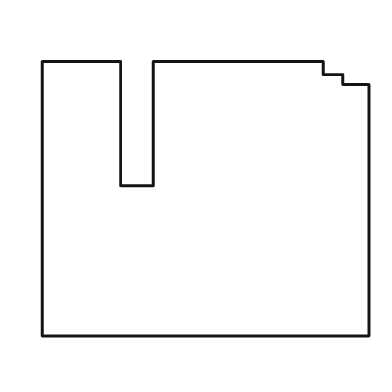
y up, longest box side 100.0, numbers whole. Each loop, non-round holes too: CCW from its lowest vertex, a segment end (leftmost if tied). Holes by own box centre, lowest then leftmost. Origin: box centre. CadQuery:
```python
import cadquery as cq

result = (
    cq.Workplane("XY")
    .moveTo(-50.0, -42.0)
    .lineTo(50.0, -42.0)
    .lineTo(50.0, 35.0)
    .lineTo(42.0, 35.0)
    .lineTo(42.0, 38.0)
    .lineTo(36.0, 38.0)
    .lineTo(36.0, 42.0)
    .lineTo(-16.0, 42.0)
    .lineTo(-16.0, 4.0)
    .lineTo(-26.0, 4.0)
    .lineTo(-26.0, 42.0)
    .lineTo(-50.0, 42.0)
    .close()
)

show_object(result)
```